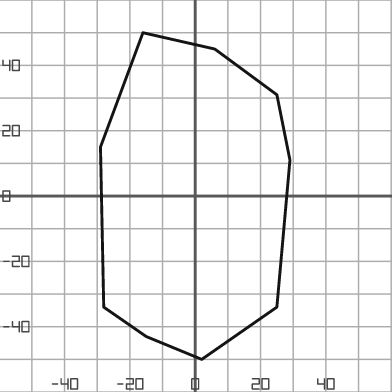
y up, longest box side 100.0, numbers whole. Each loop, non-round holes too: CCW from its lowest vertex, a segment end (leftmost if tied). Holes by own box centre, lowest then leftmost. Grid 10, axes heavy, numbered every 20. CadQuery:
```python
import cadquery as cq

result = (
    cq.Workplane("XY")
    .moveTo(2.0, -50.0)
    .lineTo(25.0, -34.0)
    .lineTo(29.0, 11.0)
    .lineTo(25.0, 31.0)
    .lineTo(6.0, 45.0)
    .lineTo(-16.0, 50.0)
    .lineTo(-29.0, 15.0)
    .lineTo(-28.0, -34.0)
    .lineTo(-15.0, -43.0)
    .close()
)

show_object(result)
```